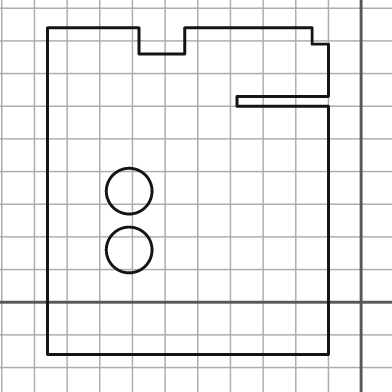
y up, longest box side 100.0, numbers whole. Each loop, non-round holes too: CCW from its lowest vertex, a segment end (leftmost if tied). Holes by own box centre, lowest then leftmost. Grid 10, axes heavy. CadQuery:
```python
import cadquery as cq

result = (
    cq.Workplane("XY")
    .moveTo(-96.0, -16.0)
    .lineTo(-10.0, -16.0)
    .lineTo(-10.0, 60.0)
    .lineTo(-38.0, 60.0)
    .lineTo(-38.0, 63.0)
    .lineTo(-10.0, 63.0)
    .lineTo(-10.0, 79.0)
    .lineTo(-15.0, 79.0)
    .lineTo(-15.0, 84.0)
    .lineTo(-54.0, 84.0)
    .lineTo(-54.0, 76.0)
    .lineTo(-68.0, 76.0)
    .lineTo(-68.0, 84.0)
    .lineTo(-96.0, 84.0)
    .close()
    .moveTo(-71.0, 16.0)
    .circle(7.0)
    .moveTo(-71.0, 34.0)
    .circle(7.0)
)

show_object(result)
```